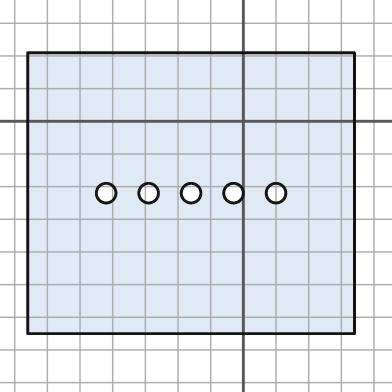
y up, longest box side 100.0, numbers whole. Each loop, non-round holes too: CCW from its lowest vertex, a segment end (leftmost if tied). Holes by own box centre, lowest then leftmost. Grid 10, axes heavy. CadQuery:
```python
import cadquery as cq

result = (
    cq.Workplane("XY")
    .moveTo(-66.0, -65.0)
    .lineTo(34.0, -65.0)
    .lineTo(34.0, 21.0)
    .lineTo(-66.0, 21.0)
    .close()
    .moveTo(-42.0, -22.0)
    .circle(3.0)
    .moveTo(-29.0, -22.0)
    .circle(3.0)
    .moveTo(-16.0, -22.0)
    .circle(3.0)
    .moveTo(-3.0, -22.0)
    .circle(3.0)
    .moveTo(10.0, -22.0)
    .circle(3.0)
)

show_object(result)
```